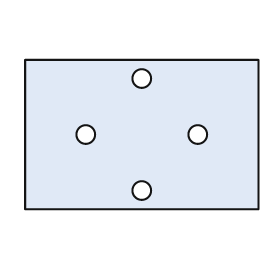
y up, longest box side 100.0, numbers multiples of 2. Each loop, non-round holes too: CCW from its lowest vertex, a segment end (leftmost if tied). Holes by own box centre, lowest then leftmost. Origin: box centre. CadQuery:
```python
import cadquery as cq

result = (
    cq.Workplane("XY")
    .moveTo(-50.0, -32.0)
    .lineTo(50.0, -32.0)
    .lineTo(50.0, 32.0)
    .lineTo(-50.0, 32.0)
    .close()
    .moveTo(0.0, -24.0)
    .circle(4.0)
    .moveTo(-24.0, 0.0)
    .circle(4.0)
    .moveTo(24.0, 0.0)
    .circle(4.0)
    .moveTo(0.0, 24.0)
    .circle(4.0)
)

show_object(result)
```